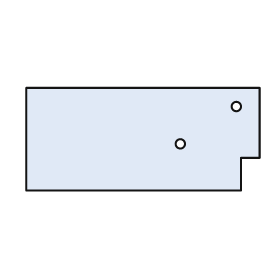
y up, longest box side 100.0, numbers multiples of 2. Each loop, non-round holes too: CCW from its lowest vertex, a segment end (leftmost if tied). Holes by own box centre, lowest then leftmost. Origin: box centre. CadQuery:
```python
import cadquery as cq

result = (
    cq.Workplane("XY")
    .moveTo(-50.0, -22.0)
    .lineTo(42.0, -22.0)
    .lineTo(42.0, -8.0)
    .lineTo(50.0, -8.0)
    .lineTo(50.0, 22.0)
    .lineTo(-50.0, 22.0)
    .close()
    .moveTo(16.0, -2.0)
    .circle(2.0)
    .moveTo(40.0, 14.0)
    .circle(2.0)
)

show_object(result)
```